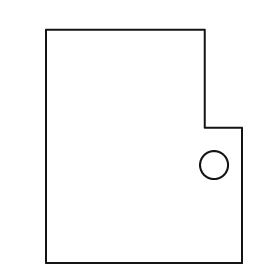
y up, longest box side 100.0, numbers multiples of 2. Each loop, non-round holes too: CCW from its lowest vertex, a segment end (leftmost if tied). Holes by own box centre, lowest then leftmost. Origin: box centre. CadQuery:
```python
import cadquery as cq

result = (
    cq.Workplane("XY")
    .moveTo(-42.0, -50.0)
    .lineTo(42.0, -50.0)
    .lineTo(42.0, 8.0)
    .lineTo(26.0, 8.0)
    .lineTo(26.0, 50.0)
    .lineTo(-42.0, 50.0)
    .close()
    .moveTo(30.0, -8.0)
    .circle(6.0)
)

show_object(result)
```